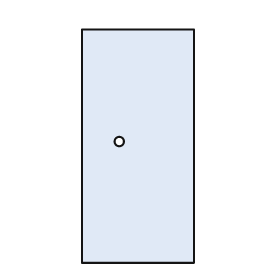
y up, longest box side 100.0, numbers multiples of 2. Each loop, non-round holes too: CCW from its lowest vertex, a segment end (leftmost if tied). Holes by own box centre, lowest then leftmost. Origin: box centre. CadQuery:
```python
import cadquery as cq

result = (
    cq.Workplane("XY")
    .moveTo(-24.0, -50.0)
    .lineTo(24.0, -50.0)
    .lineTo(24.0, 50.0)
    .lineTo(-24.0, 50.0)
    .close()
    .moveTo(-8.0, 2.0)
    .circle(2.0)
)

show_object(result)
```